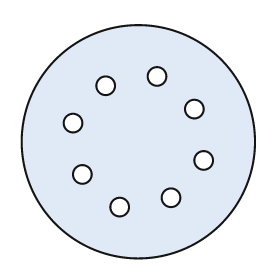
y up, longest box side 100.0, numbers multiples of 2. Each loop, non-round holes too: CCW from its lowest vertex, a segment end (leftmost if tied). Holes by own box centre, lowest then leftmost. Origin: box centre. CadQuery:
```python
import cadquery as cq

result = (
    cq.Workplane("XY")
    .moveTo(0.0, 0.0)
    .circle(50.0)
    .moveTo(-8.0, -28.0)
    .circle(4.0)
    .moveTo(14.0, -24.0)
    .circle(4.0)
    .moveTo(-24.0, -14.0)
    .circle(4.0)
    .moveTo(28.0, -8.0)
    .circle(4.0)
    .moveTo(-28.0, 8.0)
    .circle(4.0)
    .moveTo(24.0, 14.0)
    .circle(4.0)
    .moveTo(-14.0, 24.0)
    .circle(4.0)
    .moveTo(8.0, 28.0)
    .circle(4.0)
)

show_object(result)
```